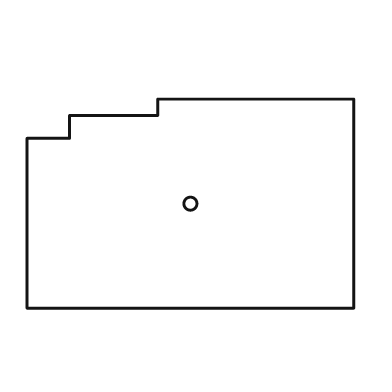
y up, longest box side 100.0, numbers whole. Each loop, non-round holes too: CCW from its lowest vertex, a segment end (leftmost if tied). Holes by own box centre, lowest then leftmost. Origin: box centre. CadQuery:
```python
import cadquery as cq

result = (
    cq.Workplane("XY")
    .moveTo(-50.0, -32.0)
    .lineTo(50.0, -32.0)
    .lineTo(50.0, 32.0)
    .lineTo(-10.0, 32.0)
    .lineTo(-10.0, 27.0)
    .lineTo(-37.0, 27.0)
    .lineTo(-37.0, 20.0)
    .lineTo(-50.0, 20.0)
    .close()
    .moveTo(0.0, 0.0)
    .circle(2.0)
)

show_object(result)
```